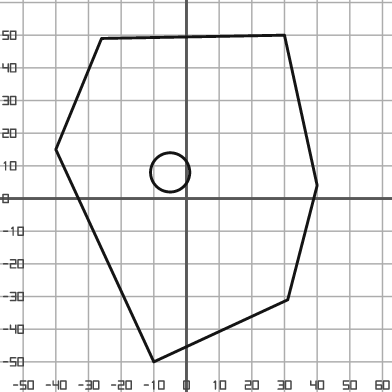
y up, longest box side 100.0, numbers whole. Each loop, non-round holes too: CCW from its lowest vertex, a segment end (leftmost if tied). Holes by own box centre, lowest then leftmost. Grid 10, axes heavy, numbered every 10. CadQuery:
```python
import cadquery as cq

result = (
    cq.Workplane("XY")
    .moveTo(-10.0, -50.0)
    .lineTo(31.0, -31.0)
    .lineTo(40.0, 4.0)
    .lineTo(30.0, 50.0)
    .lineTo(-26.0, 49.0)
    .lineTo(-40.0, 15.0)
    .close()
    .moveTo(-5.0, 8.0)
    .circle(6.0)
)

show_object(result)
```